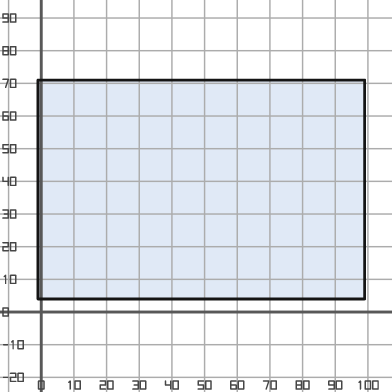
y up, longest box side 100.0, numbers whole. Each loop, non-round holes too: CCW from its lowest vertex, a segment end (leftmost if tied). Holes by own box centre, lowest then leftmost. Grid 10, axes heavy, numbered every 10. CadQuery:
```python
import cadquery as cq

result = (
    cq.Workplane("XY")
    .moveTo(-1.0, 4.0)
    .lineTo(99.0, 4.0)
    .lineTo(99.0, 71.0)
    .lineTo(-1.0, 71.0)
    .close()
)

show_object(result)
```